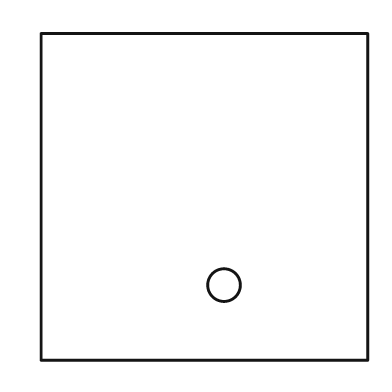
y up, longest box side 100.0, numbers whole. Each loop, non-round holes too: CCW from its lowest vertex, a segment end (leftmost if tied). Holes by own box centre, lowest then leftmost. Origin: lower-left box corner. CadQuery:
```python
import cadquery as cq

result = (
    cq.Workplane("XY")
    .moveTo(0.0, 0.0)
    .lineTo(100.0, 0.0)
    .lineTo(100.0, 100.0)
    .lineTo(0.0, 100.0)
    .close()
    .moveTo(56.0, 23.0)
    .circle(5.0)
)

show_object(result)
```